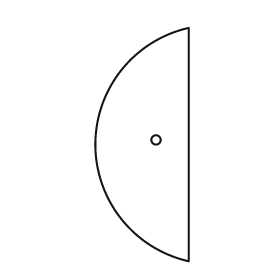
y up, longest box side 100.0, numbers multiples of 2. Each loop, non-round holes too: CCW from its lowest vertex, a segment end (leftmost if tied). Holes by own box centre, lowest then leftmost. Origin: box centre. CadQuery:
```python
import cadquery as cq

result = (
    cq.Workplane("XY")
    .moveTo(20.0, -50.0)
    .lineTo(20.0, 50.0)
    .threePointArc((-20.0, 0.0), (20.0, -50.0))
    .close()
    .moveTo(6.0, 2.0)
    .circle(2.0)
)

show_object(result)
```